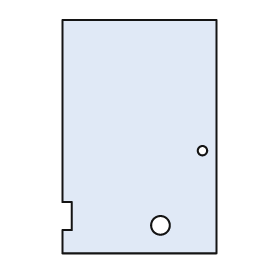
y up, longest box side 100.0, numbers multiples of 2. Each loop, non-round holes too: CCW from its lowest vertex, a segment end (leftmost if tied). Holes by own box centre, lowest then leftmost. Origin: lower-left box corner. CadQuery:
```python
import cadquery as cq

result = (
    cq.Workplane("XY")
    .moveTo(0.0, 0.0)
    .lineTo(66.0, 0.0)
    .lineTo(66.0, 100.0)
    .lineTo(0.0, 100.0)
    .lineTo(0.0, 22.0)
    .lineTo(4.0, 22.0)
    .lineTo(4.0, 10.0)
    .lineTo(0.0, 10.0)
    .close()
    .moveTo(42.0, 12.0)
    .circle(4.0)
    .moveTo(60.0, 44.0)
    .circle(2.0)
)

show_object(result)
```